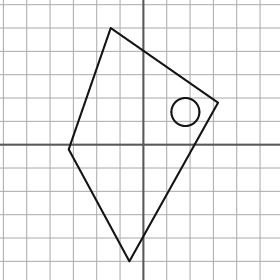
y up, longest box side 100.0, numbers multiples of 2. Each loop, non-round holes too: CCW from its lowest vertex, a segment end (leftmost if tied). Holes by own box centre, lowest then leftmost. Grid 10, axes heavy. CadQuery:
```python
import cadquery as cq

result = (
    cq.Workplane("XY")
    .moveTo(-6.0, -50.0)
    .lineTo(32.0, 18.0)
    .lineTo(-14.0, 50.0)
    .lineTo(-32.0, -2.0)
    .close()
    .moveTo(18.0, 14.0)
    .circle(6.0)
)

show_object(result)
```